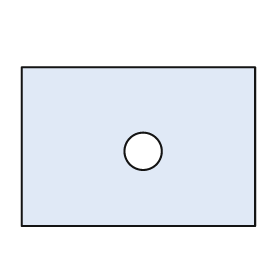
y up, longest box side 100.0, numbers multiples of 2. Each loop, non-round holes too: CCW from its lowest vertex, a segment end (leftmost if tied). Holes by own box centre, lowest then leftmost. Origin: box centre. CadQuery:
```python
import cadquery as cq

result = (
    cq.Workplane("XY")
    .moveTo(-50.0, -34.0)
    .lineTo(50.0, -34.0)
    .lineTo(50.0, 34.0)
    .lineTo(-50.0, 34.0)
    .close()
    .moveTo(2.0, -2.0)
    .circle(8.0)
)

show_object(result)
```